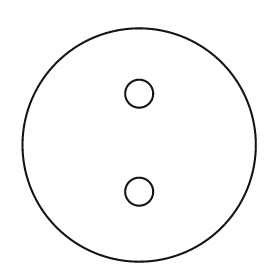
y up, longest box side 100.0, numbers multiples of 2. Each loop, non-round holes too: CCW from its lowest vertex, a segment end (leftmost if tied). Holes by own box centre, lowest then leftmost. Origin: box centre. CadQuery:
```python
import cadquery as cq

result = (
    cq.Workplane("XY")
    .moveTo(0.0, 0.0)
    .circle(50.0)
    .moveTo(0.0, -20.0)
    .circle(6.0)
    .moveTo(0.0, 22.0)
    .circle(6.0)
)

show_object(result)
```